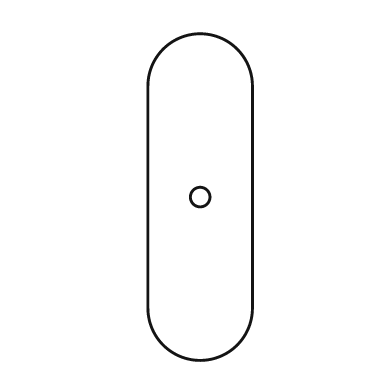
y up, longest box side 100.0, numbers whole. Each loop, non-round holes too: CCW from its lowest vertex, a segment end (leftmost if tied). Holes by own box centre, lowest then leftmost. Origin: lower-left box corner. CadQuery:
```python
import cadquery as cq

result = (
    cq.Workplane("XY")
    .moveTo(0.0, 16.0)
    .threePointArc((16.0, 0.0), (32.0, 16.0))
    .lineTo(32.0, 84.0)
    .threePointArc((16.0, 100.0), (0.0, 84.0))
    .close()
    .moveTo(16.0, 50.0)
    .circle(3.0)
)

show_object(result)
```